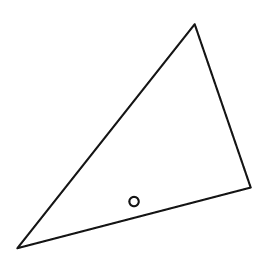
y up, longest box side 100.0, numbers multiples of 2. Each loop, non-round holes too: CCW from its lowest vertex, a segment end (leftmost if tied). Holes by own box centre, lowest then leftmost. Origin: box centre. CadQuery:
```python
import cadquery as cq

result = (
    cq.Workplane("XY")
    .moveTo(-50.0, -48.0)
    .lineTo(50.0, -22.0)
    .lineTo(26.0, 48.0)
    .close()
    .moveTo(0.0, -28.0)
    .circle(2.0)
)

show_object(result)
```